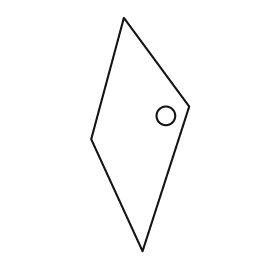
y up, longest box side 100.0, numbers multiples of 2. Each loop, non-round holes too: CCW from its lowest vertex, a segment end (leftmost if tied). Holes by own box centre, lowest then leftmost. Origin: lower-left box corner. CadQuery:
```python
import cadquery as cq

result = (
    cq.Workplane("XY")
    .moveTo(22.0, 0.0)
    .lineTo(42.0, 62.0)
    .lineTo(14.0, 100.0)
    .lineTo(0.0, 48.0)
    .close()
    .moveTo(32.0, 58.0)
    .circle(4.0)
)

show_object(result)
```